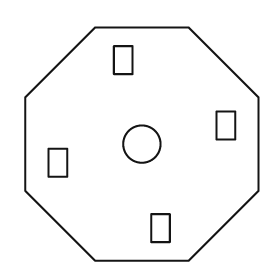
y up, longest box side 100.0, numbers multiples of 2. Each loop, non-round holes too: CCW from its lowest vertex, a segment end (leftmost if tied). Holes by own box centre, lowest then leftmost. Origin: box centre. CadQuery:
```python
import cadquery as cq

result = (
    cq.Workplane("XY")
    .moveTo(-20.0, -50.0)
    .lineTo(20.0, -50.0)
    .lineTo(50.0, -20.0)
    .lineTo(50.0, 20.0)
    .lineTo(20.0, 50.0)
    .lineTo(-20.0, 50.0)
    .lineTo(-50.0, 20.0)
    .lineTo(-50.0, -20.0)
    .close()
    .moveTo(4.0, -42.0)
    .lineTo(12.0, -42.0)
    .lineTo(12.0, -30.0)
    .lineTo(4.0, -30.0)
    .close()
    .moveTo(-40.0, -14.0)
    .lineTo(-32.0, -14.0)
    .lineTo(-32.0, -2.0)
    .lineTo(-40.0, -2.0)
    .close()
    .moveTo(0.0, 0.0)
    .circle(8.0)
    .moveTo(32.0, 2.0)
    .lineTo(40.0, 2.0)
    .lineTo(40.0, 14.0)
    .lineTo(32.0, 14.0)
    .close()
    .moveTo(-12.0, 30.0)
    .lineTo(-4.0, 30.0)
    .lineTo(-4.0, 42.0)
    .lineTo(-12.0, 42.0)
    .close()
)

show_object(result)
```